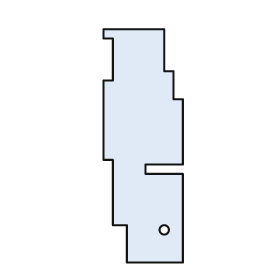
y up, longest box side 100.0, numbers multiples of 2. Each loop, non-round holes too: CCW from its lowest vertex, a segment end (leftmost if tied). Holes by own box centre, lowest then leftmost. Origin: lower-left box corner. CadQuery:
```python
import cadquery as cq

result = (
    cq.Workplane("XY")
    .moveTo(10.0, 0.0)
    .lineTo(34.0, 0.0)
    .lineTo(34.0, 38.0)
    .lineTo(18.0, 38.0)
    .lineTo(18.0, 42.0)
    .lineTo(34.0, 42.0)
    .lineTo(34.0, 70.0)
    .lineTo(30.0, 70.0)
    .lineTo(30.0, 82.0)
    .lineTo(26.0, 82.0)
    .lineTo(26.0, 100.0)
    .lineTo(0.0, 100.0)
    .lineTo(0.0, 96.0)
    .lineTo(4.0, 96.0)
    .lineTo(4.0, 78.0)
    .lineTo(0.0, 78.0)
    .lineTo(0.0, 44.0)
    .lineTo(4.0, 44.0)
    .lineTo(4.0, 16.0)
    .lineTo(10.0, 16.0)
    .close()
    .moveTo(26.0, 14.0)
    .circle(2.0)
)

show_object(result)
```